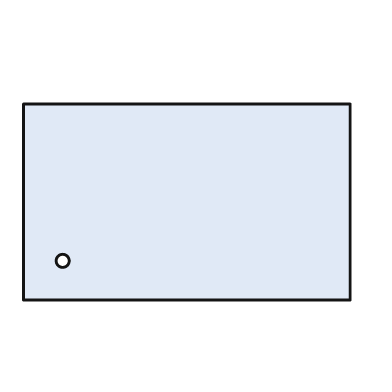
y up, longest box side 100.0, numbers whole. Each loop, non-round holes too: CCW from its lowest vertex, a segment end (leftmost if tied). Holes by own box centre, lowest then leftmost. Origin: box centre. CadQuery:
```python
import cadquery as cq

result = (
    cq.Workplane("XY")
    .moveTo(-50.0, -30.0)
    .lineTo(50.0, -30.0)
    .lineTo(50.0, 30.0)
    .lineTo(-50.0, 30.0)
    .close()
    .moveTo(-38.0, -18.0)
    .circle(2.0)
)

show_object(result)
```